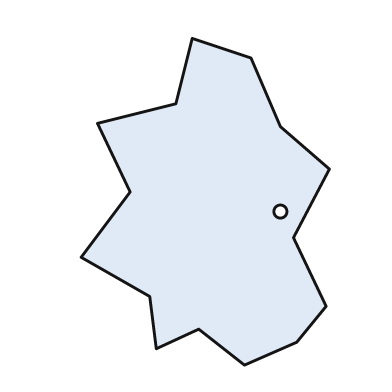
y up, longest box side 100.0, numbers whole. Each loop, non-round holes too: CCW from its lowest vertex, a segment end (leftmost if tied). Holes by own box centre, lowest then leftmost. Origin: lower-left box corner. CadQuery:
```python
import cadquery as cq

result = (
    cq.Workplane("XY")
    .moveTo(50.0, 0.0)
    .lineTo(66.0, 7.0)
    .lineTo(75.0, 18.0)
    .lineTo(65.0, 39.0)
    .lineTo(76.0, 60.0)
    .lineTo(61.0, 73.0)
    .lineTo(52.0, 94.0)
    .lineTo(34.0, 100.0)
    .lineTo(29.0, 80.0)
    .lineTo(5.0, 74.0)
    .lineTo(15.0, 53.0)
    .lineTo(0.0, 33.0)
    .lineTo(21.0, 21.0)
    .lineTo(23.0, 5.0)
    .lineTo(36.0, 11.0)
    .close()
    .moveTo(61.0, 47.0)
    .circle(2.0)
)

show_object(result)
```